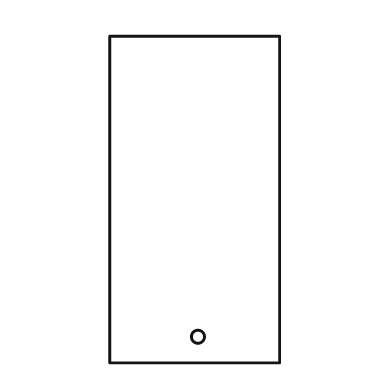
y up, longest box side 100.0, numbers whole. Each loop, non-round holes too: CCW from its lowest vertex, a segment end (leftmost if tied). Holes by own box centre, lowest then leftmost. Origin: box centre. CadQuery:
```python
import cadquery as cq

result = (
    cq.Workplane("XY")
    .moveTo(-26.0, -50.0)
    .lineTo(26.0, -50.0)
    .lineTo(26.0, 50.0)
    .lineTo(-26.0, 50.0)
    .close()
    .moveTo(1.0, -42.0)
    .circle(2.0)
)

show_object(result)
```